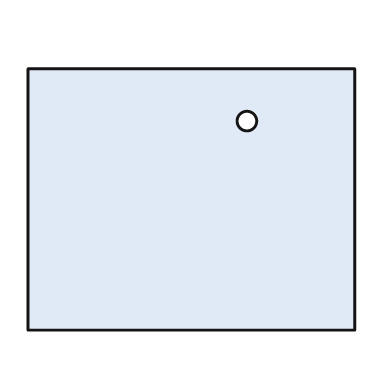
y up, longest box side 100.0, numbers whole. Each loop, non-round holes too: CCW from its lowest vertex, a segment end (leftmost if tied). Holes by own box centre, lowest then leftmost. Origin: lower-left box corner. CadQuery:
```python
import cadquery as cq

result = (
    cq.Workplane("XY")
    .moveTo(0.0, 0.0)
    .lineTo(100.0, 0.0)
    .lineTo(100.0, 80.0)
    .lineTo(0.0, 80.0)
    .close()
    .moveTo(67.0, 64.0)
    .circle(3.0)
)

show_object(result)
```